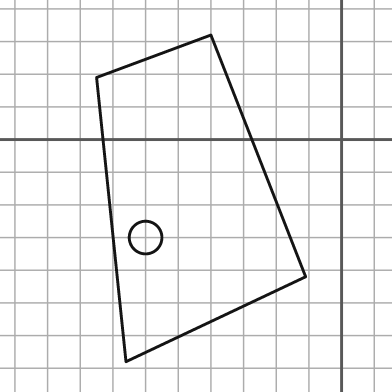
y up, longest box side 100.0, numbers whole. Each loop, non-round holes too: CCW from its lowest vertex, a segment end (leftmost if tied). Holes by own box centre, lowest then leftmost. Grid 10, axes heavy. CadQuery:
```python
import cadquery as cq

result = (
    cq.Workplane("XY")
    .moveTo(-66.0, -68.0)
    .lineTo(-11.0, -42.0)
    .lineTo(-40.0, 32.0)
    .lineTo(-75.0, 19.0)
    .close()
    .moveTo(-60.0, -30.0)
    .circle(5.0)
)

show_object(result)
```